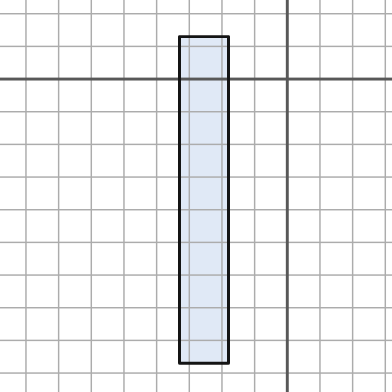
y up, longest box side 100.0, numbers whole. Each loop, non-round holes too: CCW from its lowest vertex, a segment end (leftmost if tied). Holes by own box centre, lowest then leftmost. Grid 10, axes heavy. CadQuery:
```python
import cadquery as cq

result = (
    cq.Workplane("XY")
    .moveTo(-33.0, -87.0)
    .lineTo(-18.0, -87.0)
    .lineTo(-18.0, 13.0)
    .lineTo(-33.0, 13.0)
    .close()
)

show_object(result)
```